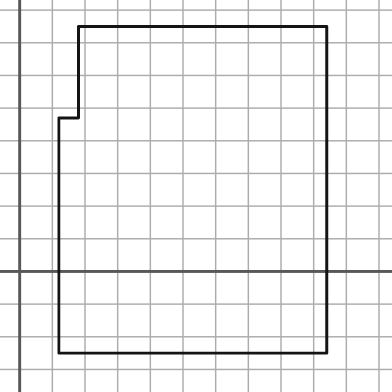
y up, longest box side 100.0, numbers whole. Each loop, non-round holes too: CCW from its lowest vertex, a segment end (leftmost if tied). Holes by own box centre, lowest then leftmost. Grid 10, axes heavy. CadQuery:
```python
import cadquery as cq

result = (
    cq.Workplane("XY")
    .moveTo(12.0, -25.0)
    .lineTo(94.0, -25.0)
    .lineTo(94.0, 75.0)
    .lineTo(18.0, 75.0)
    .lineTo(18.0, 47.0)
    .lineTo(12.0, 47.0)
    .close()
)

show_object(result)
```